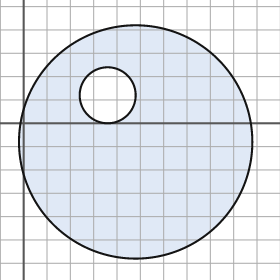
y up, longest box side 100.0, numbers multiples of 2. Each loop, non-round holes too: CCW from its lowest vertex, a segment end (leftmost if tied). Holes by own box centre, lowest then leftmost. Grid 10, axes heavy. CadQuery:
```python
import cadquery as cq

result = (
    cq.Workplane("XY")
    .moveTo(48.0, -8.0)
    .circle(50.0)
    .moveTo(36.0, 12.0)
    .circle(12.0)
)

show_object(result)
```